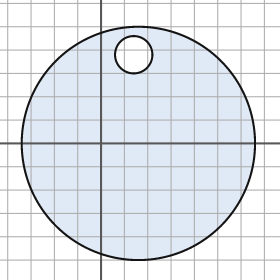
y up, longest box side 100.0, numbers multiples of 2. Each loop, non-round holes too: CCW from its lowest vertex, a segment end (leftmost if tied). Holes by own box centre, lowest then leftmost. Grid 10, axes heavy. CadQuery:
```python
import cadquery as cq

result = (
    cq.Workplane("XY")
    .moveTo(16.0, 0.0)
    .circle(50.0)
    .moveTo(14.0, 38.0)
    .circle(8.0)
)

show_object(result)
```